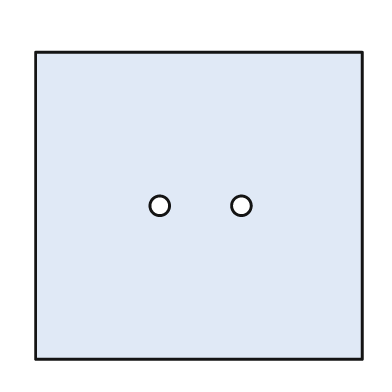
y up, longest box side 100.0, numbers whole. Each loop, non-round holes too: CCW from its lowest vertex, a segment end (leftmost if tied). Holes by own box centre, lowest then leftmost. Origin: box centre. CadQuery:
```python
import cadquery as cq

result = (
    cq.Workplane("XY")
    .moveTo(-50.0, -47.0)
    .lineTo(50.0, -47.0)
    .lineTo(50.0, 47.0)
    .lineTo(-50.0, 47.0)
    .close()
    .moveTo(-12.0, 0.0)
    .circle(3.0)
    .moveTo(13.0, 0.0)
    .circle(3.0)
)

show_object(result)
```